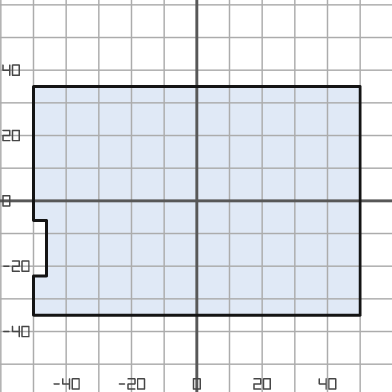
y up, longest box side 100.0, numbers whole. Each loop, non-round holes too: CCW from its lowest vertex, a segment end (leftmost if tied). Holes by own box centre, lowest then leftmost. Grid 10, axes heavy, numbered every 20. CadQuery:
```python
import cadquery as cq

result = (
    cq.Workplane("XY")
    .moveTo(-50.0, -35.0)
    .lineTo(50.0, -35.0)
    .lineTo(50.0, 35.0)
    .lineTo(-50.0, 35.0)
    .lineTo(-50.0, -6.0)
    .lineTo(-46.0, -6.0)
    .lineTo(-46.0, -23.0)
    .lineTo(-50.0, -23.0)
    .close()
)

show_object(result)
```